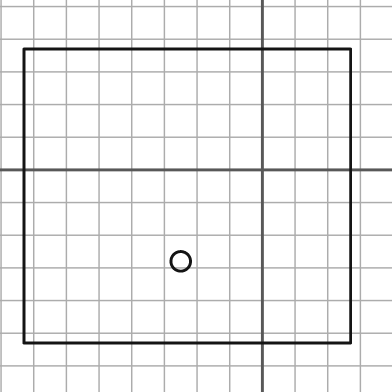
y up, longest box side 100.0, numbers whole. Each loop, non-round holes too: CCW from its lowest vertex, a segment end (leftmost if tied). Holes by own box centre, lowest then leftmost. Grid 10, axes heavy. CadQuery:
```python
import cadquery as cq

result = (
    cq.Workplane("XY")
    .moveTo(-73.0, -53.0)
    .lineTo(27.0, -53.0)
    .lineTo(27.0, 37.0)
    .lineTo(-73.0, 37.0)
    .close()
    .moveTo(-25.0, -28.0)
    .circle(3.0)
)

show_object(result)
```